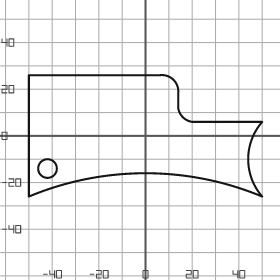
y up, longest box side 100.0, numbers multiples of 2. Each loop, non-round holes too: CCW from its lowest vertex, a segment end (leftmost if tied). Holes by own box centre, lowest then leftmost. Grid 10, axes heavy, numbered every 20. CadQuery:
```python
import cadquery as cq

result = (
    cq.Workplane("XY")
    .moveTo(-50.0, -26.0)
    .threePointArc((0.0, -16.0), (50.0, -26.0))
    .threePointArc((44.0, -10.0), (50.0, 6.0))
    .lineTo(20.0, 6.0)
    .threePointArc((16.0, 8.0), (14.0, 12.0))
    .lineTo(14.0, 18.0)
    .threePointArc((12.0, 24.0), (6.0, 26.0))
    .lineTo(-50.0, 26.0)
    .close()
    .moveTo(-42.0, -14.0)
    .circle(4.0)
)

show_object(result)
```